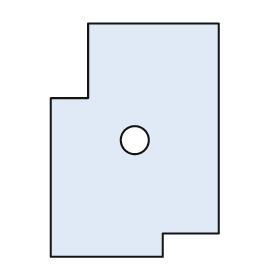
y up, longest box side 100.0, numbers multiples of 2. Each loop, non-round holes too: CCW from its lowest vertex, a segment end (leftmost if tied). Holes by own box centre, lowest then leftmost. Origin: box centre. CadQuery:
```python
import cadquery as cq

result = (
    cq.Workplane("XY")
    .moveTo(-36.0, -50.0)
    .lineTo(12.0, -50.0)
    .lineTo(12.0, -40.0)
    .lineTo(36.0, -40.0)
    .lineTo(36.0, 50.0)
    .lineTo(-20.0, 50.0)
    .lineTo(-20.0, 18.0)
    .lineTo(-36.0, 18.0)
    .close()
    .moveTo(0.0, 0.0)
    .circle(6.0)
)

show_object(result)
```